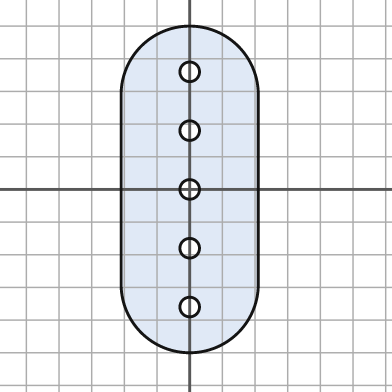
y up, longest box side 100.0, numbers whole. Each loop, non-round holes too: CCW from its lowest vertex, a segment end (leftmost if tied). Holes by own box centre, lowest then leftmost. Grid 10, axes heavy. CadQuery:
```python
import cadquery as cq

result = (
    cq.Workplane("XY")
    .moveTo(-21.0, -29.0)
    .threePointArc((0.0, -50.0), (21.0, -29.0))
    .lineTo(21.0, 29.0)
    .threePointArc((0.0, 50.0), (-21.0, 29.0))
    .close()
    .moveTo(0.0, -36.0)
    .circle(3.0)
    .moveTo(0.0, -18.0)
    .circle(3.0)
    .moveTo(0.0, 0.0)
    .circle(3.0)
    .moveTo(0.0, 18.0)
    .circle(3.0)
    .moveTo(0.0, 36.0)
    .circle(3.0)
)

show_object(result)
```